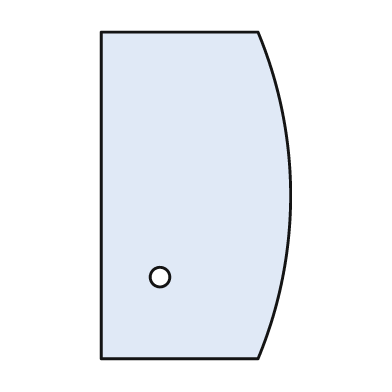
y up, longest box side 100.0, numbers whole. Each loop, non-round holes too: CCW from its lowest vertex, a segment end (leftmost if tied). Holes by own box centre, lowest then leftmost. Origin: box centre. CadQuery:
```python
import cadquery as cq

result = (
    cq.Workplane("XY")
    .moveTo(-29.0, -50.0)
    .lineTo(19.0, -50.0)
    .threePointArc((29.0, 0.0), (19.0, 50.0))
    .lineTo(-29.0, 50.0)
    .close()
    .moveTo(-11.0, -25.0)
    .circle(3.0)
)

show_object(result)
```